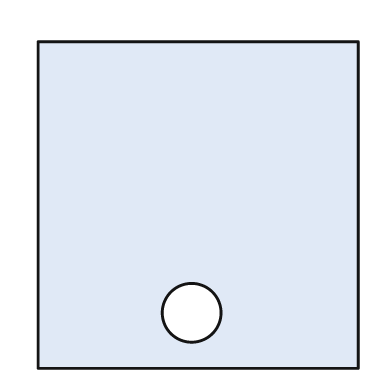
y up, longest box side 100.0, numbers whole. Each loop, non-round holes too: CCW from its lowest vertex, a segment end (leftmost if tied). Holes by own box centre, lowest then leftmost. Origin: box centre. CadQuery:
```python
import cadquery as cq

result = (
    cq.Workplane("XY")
    .moveTo(-49.0, -50.0)
    .lineTo(49.0, -50.0)
    .lineTo(49.0, 50.0)
    .lineTo(-49.0, 50.0)
    .close()
    .moveTo(-2.0, -33.0)
    .circle(9.0)
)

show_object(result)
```